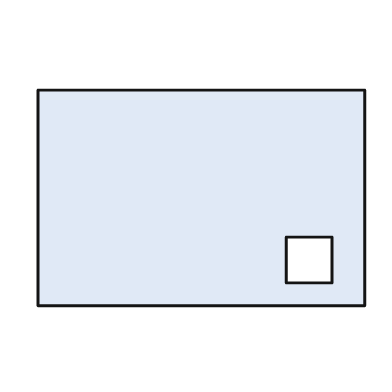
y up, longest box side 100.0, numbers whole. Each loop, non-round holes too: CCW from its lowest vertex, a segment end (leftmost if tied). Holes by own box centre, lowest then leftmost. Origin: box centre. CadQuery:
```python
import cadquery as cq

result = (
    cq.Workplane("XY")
    .moveTo(-50.0, -33.0)
    .lineTo(50.0, -33.0)
    .lineTo(50.0, 33.0)
    .lineTo(-50.0, 33.0)
    .close()
    .moveTo(26.0, -26.0)
    .lineTo(40.0, -26.0)
    .lineTo(40.0, -12.0)
    .lineTo(26.0, -12.0)
    .close()
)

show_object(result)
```